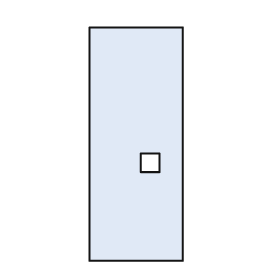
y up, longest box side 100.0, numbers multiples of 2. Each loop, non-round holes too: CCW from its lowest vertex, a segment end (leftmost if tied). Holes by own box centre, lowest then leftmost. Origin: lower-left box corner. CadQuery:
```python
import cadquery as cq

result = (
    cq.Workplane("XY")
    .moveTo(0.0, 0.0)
    .lineTo(40.0, 0.0)
    .lineTo(40.0, 100.0)
    .lineTo(0.0, 100.0)
    .close()
    .moveTo(22.0, 38.0)
    .lineTo(30.0, 38.0)
    .lineTo(30.0, 46.0)
    .lineTo(22.0, 46.0)
    .close()
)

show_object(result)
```